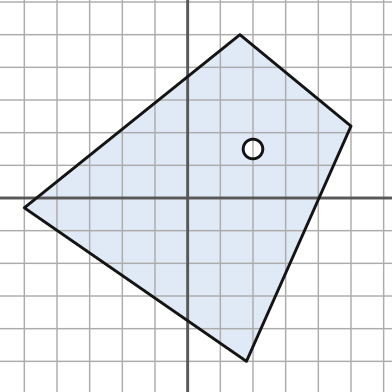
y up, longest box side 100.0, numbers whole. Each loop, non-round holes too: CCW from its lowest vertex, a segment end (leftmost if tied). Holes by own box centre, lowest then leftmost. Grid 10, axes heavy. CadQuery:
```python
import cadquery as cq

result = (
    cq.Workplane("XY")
    .moveTo(18.0, -50.0)
    .lineTo(50.0, 22.0)
    .lineTo(16.0, 50.0)
    .lineTo(-50.0, -3.0)
    .close()
    .moveTo(20.0, 15.0)
    .circle(3.0)
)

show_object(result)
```